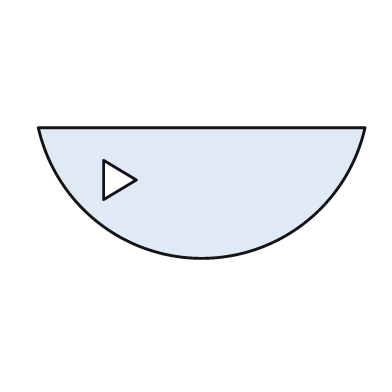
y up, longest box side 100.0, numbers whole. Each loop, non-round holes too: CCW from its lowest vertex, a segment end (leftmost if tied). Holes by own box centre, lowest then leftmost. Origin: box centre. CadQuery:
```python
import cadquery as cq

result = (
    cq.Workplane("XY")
    .moveTo(-50.0, 20.0)
    .threePointArc((0.0, -20.0), (50.0, 20.0))
    .close()
    .moveTo(-30.0, -2.0)
    .lineTo(-20.0, 4.0)
    .lineTo(-30.0, 10.0)
    .close()
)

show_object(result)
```